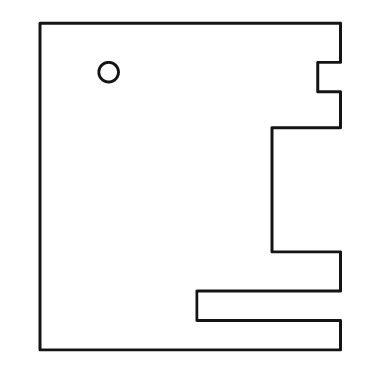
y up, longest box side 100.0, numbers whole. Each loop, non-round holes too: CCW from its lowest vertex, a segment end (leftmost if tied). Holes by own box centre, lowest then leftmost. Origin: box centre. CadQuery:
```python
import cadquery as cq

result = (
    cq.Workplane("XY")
    .moveTo(-46.0, -50.0)
    .lineTo(46.0, -50.0)
    .lineTo(46.0, -41.0)
    .lineTo(2.0, -41.0)
    .lineTo(2.0, -32.0)
    .lineTo(46.0, -32.0)
    .lineTo(46.0, -20.0)
    .lineTo(25.0, -20.0)
    .lineTo(25.0, 18.0)
    .lineTo(46.0, 18.0)
    .lineTo(46.0, 29.0)
    .lineTo(39.0, 29.0)
    .lineTo(39.0, 38.0)
    .lineTo(46.0, 38.0)
    .lineTo(46.0, 50.0)
    .lineTo(-46.0, 50.0)
    .close()
    .moveTo(-25.0, 35.0)
    .circle(3.0)
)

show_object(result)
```